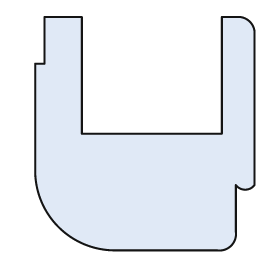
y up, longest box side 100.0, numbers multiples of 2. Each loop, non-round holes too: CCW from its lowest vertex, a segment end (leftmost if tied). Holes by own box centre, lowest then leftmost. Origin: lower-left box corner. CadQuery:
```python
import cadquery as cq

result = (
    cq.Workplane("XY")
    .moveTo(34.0, 0.0)
    .lineTo(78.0, 0.0)
    .threePointArc((84.0, 2.0), (86.0, 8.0))
    .lineTo(86.0, 28.0)
    .threePointArc((90.0, 26.0), (94.0, 28.0))
    .lineTo(94.0, 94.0)
    .threePointArc((92.0, 98.0), (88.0, 100.0))
    .lineTo(80.0, 100.0)
    .lineTo(80.0, 50.0)
    .lineTo(20.0, 50.0)
    .lineTo(20.0, 100.0)
    .lineTo(4.0, 100.0)
    .lineTo(4.0, 80.0)
    .lineTo(0.0, 80.0)
    .lineTo(0.0, 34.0)
    .threePointArc((10.0, 10.0), (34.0, 0.0))
    .close()
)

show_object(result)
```